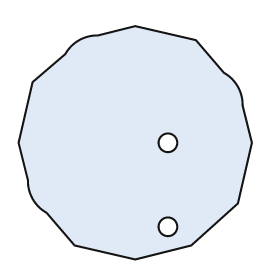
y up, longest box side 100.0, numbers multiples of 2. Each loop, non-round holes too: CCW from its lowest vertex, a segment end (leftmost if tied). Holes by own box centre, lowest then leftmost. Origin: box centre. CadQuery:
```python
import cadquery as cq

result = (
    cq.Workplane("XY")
    .moveTo(0.0, -50.0)
    .lineTo(24.0, -44.0)
    .lineTo(44.0, -26.0)
    .lineTo(50.0, 0.0)
    .lineTo(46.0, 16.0)
    .threePointArc((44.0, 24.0), (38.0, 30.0))
    .lineTo(26.0, 44.0)
    .lineTo(0.0, 50.0)
    .lineTo(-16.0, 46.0)
    .threePointArc((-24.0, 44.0), (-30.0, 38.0))
    .lineTo(-44.0, 26.0)
    .lineTo(-50.0, 0.0)
    .lineTo(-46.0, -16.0)
    .threePointArc((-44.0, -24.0), (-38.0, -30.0))
    .lineTo(-26.0, -44.0)
    .close()
    .moveTo(14.0, -36.0)
    .circle(4.0)
    .moveTo(14.0, 0.0)
    .circle(4.0)
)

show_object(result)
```